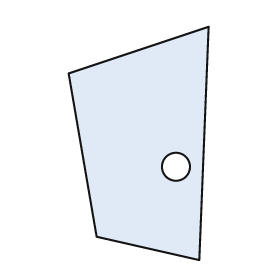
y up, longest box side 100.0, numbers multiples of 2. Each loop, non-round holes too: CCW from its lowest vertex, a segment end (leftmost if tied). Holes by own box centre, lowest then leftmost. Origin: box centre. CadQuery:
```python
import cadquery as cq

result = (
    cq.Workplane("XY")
    .moveTo(26.0, -50.0)
    .lineTo(30.0, 50.0)
    .lineTo(-30.0, 30.0)
    .lineTo(-18.0, -40.0)
    .close()
    .moveTo(16.0, -10.0)
    .circle(6.0)
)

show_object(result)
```